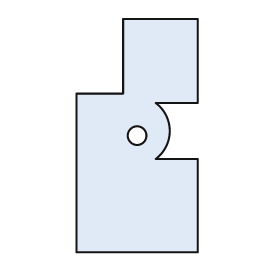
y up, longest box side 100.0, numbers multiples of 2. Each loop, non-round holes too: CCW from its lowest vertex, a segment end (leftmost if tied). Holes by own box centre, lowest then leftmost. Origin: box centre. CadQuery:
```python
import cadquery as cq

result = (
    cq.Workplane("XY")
    .moveTo(-26.0, -50.0)
    .lineTo(26.0, -50.0)
    .lineTo(26.0, -10.0)
    .lineTo(8.0, -10.0)
    .threePointArc((14.0, 2.0), (8.0, 14.0))
    .lineTo(26.0, 14.0)
    .lineTo(26.0, 50.0)
    .lineTo(-6.0, 50.0)
    .lineTo(-6.0, 18.0)
    .lineTo(-26.0, 18.0)
    .close()
    .moveTo(0.0, 0.0)
    .circle(4.0)
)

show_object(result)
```